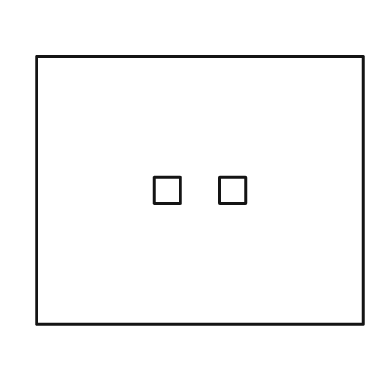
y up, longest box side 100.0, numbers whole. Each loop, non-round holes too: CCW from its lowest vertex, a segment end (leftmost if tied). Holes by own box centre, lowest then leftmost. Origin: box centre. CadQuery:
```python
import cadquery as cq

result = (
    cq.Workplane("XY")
    .moveTo(-50.0, -41.0)
    .lineTo(50.0, -41.0)
    .lineTo(50.0, 41.0)
    .lineTo(-50.0, 41.0)
    .close()
    .moveTo(-14.0, -4.0)
    .lineTo(-6.0, -4.0)
    .lineTo(-6.0, 4.0)
    .lineTo(-14.0, 4.0)
    .close()
    .moveTo(6.0, -4.0)
    .lineTo(14.0, -4.0)
    .lineTo(14.0, 4.0)
    .lineTo(6.0, 4.0)
    .close()
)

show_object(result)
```